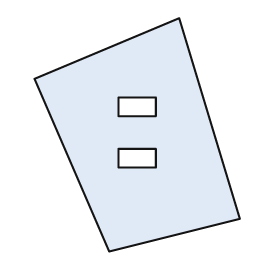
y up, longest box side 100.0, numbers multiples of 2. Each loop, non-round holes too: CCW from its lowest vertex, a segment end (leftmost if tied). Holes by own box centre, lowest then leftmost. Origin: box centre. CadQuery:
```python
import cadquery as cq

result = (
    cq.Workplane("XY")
    .moveTo(-12.0, -50.0)
    .lineTo(44.0, -36.0)
    .lineTo(18.0, 50.0)
    .lineTo(-44.0, 24.0)
    .close()
    .moveTo(-8.0, -14.0)
    .lineTo(8.0, -14.0)
    .lineTo(8.0, -6.0)
    .lineTo(-8.0, -6.0)
    .close()
    .moveTo(-8.0, 8.0)
    .lineTo(8.0, 8.0)
    .lineTo(8.0, 16.0)
    .lineTo(-8.0, 16.0)
    .close()
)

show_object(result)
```